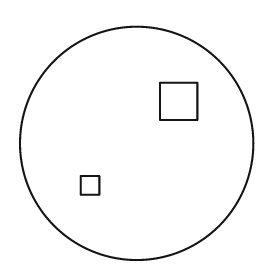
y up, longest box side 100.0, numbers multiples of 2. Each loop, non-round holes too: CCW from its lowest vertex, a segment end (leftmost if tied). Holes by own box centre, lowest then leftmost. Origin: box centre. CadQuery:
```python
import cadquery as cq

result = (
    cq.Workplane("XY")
    .moveTo(0.0, 0.0)
    .circle(50.0)
    .moveTo(-24.0, -22.0)
    .lineTo(-16.0, -22.0)
    .lineTo(-16.0, -14.0)
    .lineTo(-24.0, -14.0)
    .close()
    .moveTo(10.0, 10.0)
    .lineTo(26.0, 10.0)
    .lineTo(26.0, 26.0)
    .lineTo(10.0, 26.0)
    .close()
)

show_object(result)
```